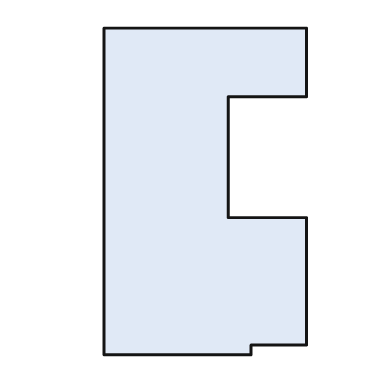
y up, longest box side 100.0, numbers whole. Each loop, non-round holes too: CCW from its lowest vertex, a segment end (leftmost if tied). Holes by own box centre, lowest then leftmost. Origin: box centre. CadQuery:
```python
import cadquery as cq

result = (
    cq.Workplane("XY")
    .moveTo(-31.0, -50.0)
    .lineTo(14.0, -50.0)
    .lineTo(14.0, -47.0)
    .lineTo(31.0, -47.0)
    .lineTo(31.0, -8.0)
    .lineTo(7.0, -8.0)
    .lineTo(7.0, 29.0)
    .lineTo(31.0, 29.0)
    .lineTo(31.0, 50.0)
    .lineTo(-31.0, 50.0)
    .close()
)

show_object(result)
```